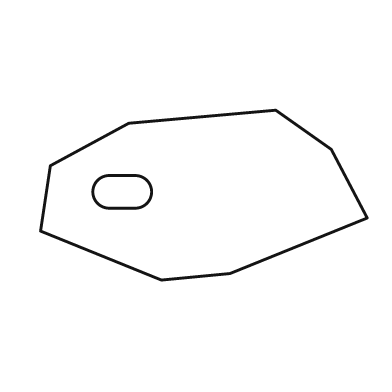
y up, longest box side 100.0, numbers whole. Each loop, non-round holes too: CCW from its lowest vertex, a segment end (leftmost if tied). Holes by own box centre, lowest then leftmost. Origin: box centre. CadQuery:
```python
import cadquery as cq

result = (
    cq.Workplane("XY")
    .moveTo(-13.0, -26.0)
    .lineTo(8.0, -24.0)
    .lineTo(50.0, -7.0)
    .lineTo(39.0, 14.0)
    .lineTo(22.0, 26.0)
    .lineTo(-23.0, 22.0)
    .lineTo(-47.0, 9.0)
    .lineTo(-50.0, -11.0)
    .close()
    .moveTo(-29.0, -4.0)
    .lineTo(-21.0, -4.0)
    .threePointArc((-16.0, 1.0), (-21.0, 6.0))
    .lineTo(-29.0, 6.0)
    .threePointArc((-34.0, 1.0), (-29.0, -4.0))
    .close()
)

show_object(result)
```